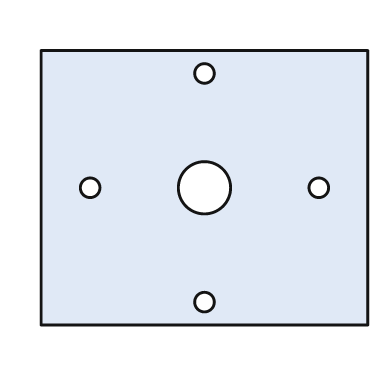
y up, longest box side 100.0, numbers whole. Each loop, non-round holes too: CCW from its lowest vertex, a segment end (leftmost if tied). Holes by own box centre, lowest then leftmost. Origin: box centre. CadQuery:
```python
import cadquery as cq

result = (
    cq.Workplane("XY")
    .moveTo(-50.0, -42.0)
    .lineTo(50.0, -42.0)
    .lineTo(50.0, 42.0)
    .lineTo(-50.0, 42.0)
    .close()
    .moveTo(0.0, -35.0)
    .circle(3.0)
    .moveTo(-35.0, 0.0)
    .circle(3.0)
    .moveTo(0.0, 0.0)
    .circle(8.0)
    .moveTo(35.0, 0.0)
    .circle(3.0)
    .moveTo(0.0, 35.0)
    .circle(3.0)
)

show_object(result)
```